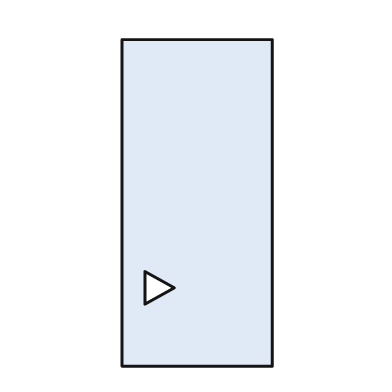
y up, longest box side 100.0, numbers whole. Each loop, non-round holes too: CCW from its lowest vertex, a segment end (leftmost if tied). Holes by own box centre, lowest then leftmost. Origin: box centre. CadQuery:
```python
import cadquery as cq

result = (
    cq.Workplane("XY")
    .moveTo(-23.0, -50.0)
    .lineTo(23.0, -50.0)
    .lineTo(23.0, 50.0)
    .lineTo(-23.0, 50.0)
    .close()
    .moveTo(-16.0, -31.0)
    .lineTo(-7.0, -26.0)
    .lineTo(-16.0, -21.0)
    .close()
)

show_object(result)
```